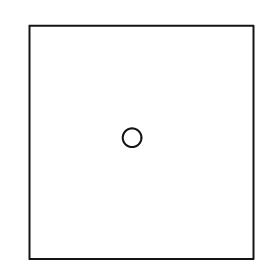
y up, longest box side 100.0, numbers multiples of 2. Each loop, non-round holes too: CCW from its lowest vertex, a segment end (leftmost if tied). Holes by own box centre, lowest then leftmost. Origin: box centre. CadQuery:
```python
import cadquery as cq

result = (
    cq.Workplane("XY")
    .moveTo(-48.0, -50.0)
    .lineTo(48.0, -50.0)
    .lineTo(48.0, 50.0)
    .lineTo(-48.0, 50.0)
    .close()
    .moveTo(-4.0, 2.0)
    .circle(4.0)
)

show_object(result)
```